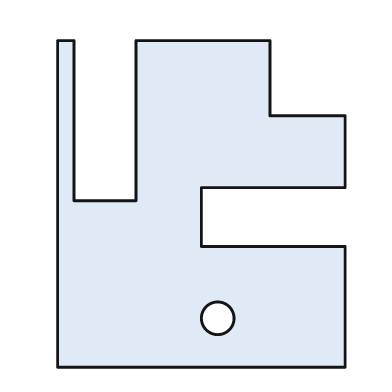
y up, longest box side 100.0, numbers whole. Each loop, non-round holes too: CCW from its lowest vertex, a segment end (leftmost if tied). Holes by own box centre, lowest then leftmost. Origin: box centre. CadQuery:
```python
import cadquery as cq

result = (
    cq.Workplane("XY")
    .moveTo(-44.0, -50.0)
    .lineTo(44.0, -50.0)
    .lineTo(44.0, -13.0)
    .lineTo(0.0, -13.0)
    .lineTo(0.0, 5.0)
    .lineTo(44.0, 5.0)
    .lineTo(44.0, 27.0)
    .lineTo(21.0, 27.0)
    .lineTo(21.0, 50.0)
    .lineTo(-20.0, 50.0)
    .lineTo(-20.0, 1.0)
    .lineTo(-39.0, 1.0)
    .lineTo(-39.0, 50.0)
    .lineTo(-44.0, 50.0)
    .close()
    .moveTo(5.0, -35.0)
    .circle(5.0)
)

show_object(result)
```